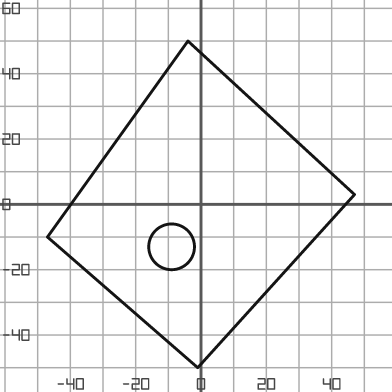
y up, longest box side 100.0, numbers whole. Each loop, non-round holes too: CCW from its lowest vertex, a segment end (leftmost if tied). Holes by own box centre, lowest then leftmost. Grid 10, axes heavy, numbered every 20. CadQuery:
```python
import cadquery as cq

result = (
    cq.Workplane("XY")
    .moveTo(-1.0, -50.0)
    .lineTo(47.0, 3.0)
    .lineTo(-4.0, 50.0)
    .lineTo(-47.0, -10.0)
    .close()
    .moveTo(-9.0, -13.0)
    .circle(7.0)
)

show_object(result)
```